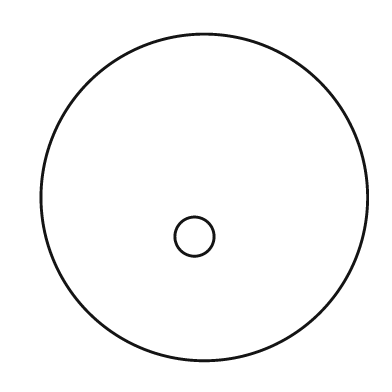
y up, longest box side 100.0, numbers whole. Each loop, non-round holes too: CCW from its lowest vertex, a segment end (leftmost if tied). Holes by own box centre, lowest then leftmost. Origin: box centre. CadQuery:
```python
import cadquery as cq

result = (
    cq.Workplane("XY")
    .moveTo(0.0, 0.0)
    .circle(50.0)
    .moveTo(-3.0, -12.0)
    .circle(6.0)
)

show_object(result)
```